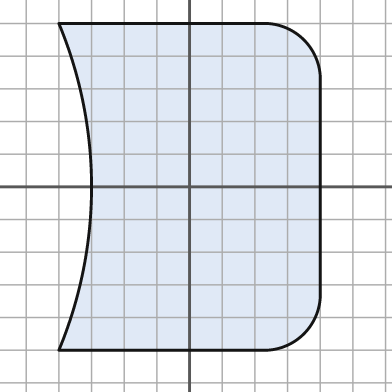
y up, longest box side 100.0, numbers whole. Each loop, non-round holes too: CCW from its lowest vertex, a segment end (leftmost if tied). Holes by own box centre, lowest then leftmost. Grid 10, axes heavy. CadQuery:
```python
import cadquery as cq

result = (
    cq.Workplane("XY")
    .moveTo(-40.0, -50.0)
    .lineTo(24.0, -50.0)
    .threePointArc((35.0, -45.0), (40.0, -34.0))
    .lineTo(40.0, 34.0)
    .threePointArc((35.0, 45.0), (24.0, 50.0))
    .lineTo(-40.0, 50.0)
    .threePointArc((-30.0, 0.0), (-40.0, -50.0))
    .close()
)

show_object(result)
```